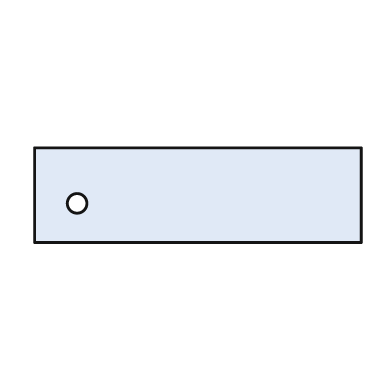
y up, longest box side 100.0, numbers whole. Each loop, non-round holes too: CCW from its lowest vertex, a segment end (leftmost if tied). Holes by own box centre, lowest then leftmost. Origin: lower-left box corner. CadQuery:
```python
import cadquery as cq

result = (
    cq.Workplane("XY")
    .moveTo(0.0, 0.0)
    .lineTo(100.0, 0.0)
    .lineTo(100.0, 29.0)
    .lineTo(0.0, 29.0)
    .close()
    .moveTo(13.0, 12.0)
    .circle(3.0)
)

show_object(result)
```